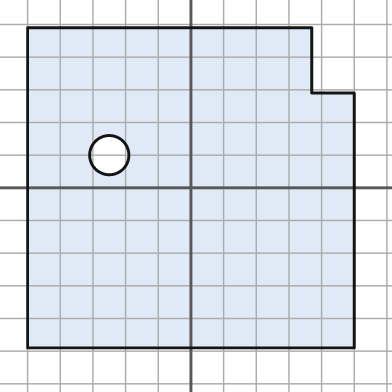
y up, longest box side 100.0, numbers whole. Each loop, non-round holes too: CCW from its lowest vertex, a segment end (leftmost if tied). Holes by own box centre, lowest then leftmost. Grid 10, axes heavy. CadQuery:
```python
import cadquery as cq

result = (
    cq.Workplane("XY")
    .moveTo(-50.0, -49.0)
    .lineTo(50.0, -49.0)
    .lineTo(50.0, 29.0)
    .lineTo(37.0, 29.0)
    .lineTo(37.0, 49.0)
    .lineTo(-50.0, 49.0)
    .close()
    .moveTo(-25.0, 10.0)
    .circle(6.0)
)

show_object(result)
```